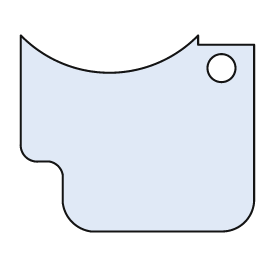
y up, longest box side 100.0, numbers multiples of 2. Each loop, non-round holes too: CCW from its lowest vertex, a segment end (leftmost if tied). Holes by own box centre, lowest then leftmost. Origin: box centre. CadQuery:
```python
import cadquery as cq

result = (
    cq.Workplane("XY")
    .moveTo(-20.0, -42.0)
    .lineTo(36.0, -42.0)
    .threePointArc((46.0, -38.0), (50.0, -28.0))
    .lineTo(50.0, 38.0)
    .lineTo(26.0, 38.0)
    .lineTo(26.0, 42.0)
    .threePointArc((-12.0, 26.0), (-50.0, 42.0))
    .lineTo(-50.0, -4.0)
    .threePointArc((-48.0, -10.0), (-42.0, -12.0))
    .lineTo(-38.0, -12.0)
    .threePointArc((-34.0, -14.0), (-32.0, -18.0))
    .lineTo(-32.0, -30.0)
    .threePointArc((-28.0, -38.0), (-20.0, -42.0))
    .close()
    .moveTo(36.0, 28.0)
    .circle(6.0)
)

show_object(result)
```